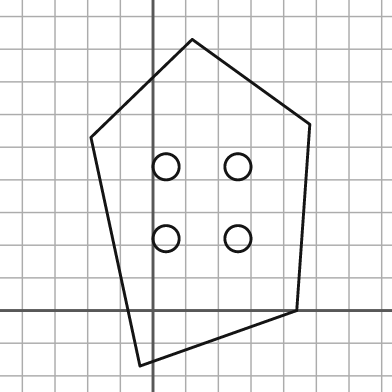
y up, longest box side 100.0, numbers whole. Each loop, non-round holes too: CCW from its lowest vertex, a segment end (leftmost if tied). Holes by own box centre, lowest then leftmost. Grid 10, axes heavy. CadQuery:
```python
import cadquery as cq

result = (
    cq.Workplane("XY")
    .moveTo(-4.0, -17.0)
    .lineTo(44.0, 0.0)
    .lineTo(48.0, 57.0)
    .lineTo(12.0, 83.0)
    .lineTo(-19.0, 53.0)
    .close()
    .moveTo(4.0, 22.0)
    .circle(4.0)
    .moveTo(26.0, 22.0)
    .circle(4.0)
    .moveTo(4.0, 44.0)
    .circle(4.0)
    .moveTo(26.0, 44.0)
    .circle(4.0)
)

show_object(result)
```